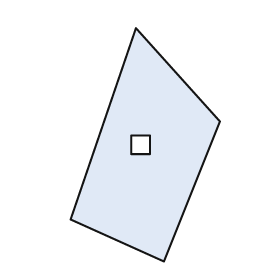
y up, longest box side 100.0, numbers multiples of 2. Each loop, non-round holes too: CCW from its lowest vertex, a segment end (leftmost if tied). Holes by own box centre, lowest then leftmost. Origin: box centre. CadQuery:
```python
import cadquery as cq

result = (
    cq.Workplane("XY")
    .moveTo(8.0, -50.0)
    .lineTo(32.0, 10.0)
    .lineTo(-4.0, 50.0)
    .lineTo(-32.0, -32.0)
    .close()
    .moveTo(-6.0, -4.0)
    .lineTo(2.0, -4.0)
    .lineTo(2.0, 4.0)
    .lineTo(-6.0, 4.0)
    .close()
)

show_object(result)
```